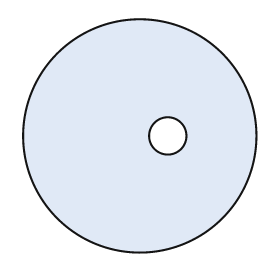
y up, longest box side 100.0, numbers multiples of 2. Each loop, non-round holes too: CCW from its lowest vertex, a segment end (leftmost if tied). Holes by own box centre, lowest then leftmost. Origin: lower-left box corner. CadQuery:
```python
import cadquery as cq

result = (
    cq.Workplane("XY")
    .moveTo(50.0, 50.0)
    .circle(50.0)
    .moveTo(62.0, 50.0)
    .circle(8.0)
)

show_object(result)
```